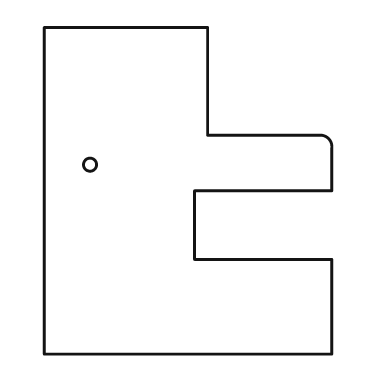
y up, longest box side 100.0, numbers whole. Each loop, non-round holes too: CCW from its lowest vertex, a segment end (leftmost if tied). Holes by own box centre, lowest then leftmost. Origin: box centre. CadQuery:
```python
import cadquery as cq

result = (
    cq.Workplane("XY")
    .moveTo(-44.0, -50.0)
    .lineTo(44.0, -50.0)
    .lineTo(44.0, -21.0)
    .lineTo(2.0, -21.0)
    .lineTo(2.0, 0.0)
    .lineTo(44.0, 0.0)
    .lineTo(44.0, 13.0)
    .threePointArc((43.0, 16.0), (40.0, 17.0))
    .lineTo(6.0, 17.0)
    .lineTo(6.0, 50.0)
    .lineTo(-44.0, 50.0)
    .close()
    .moveTo(-30.0, 8.0)
    .circle(2.0)
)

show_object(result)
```